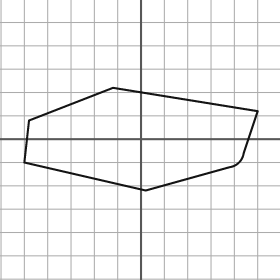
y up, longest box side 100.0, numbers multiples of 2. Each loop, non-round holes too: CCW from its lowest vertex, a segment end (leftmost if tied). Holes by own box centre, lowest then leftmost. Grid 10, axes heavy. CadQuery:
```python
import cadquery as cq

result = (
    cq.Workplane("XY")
    .moveTo(2.0, -22.0)
    .lineTo(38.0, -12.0)
    .threePointArc((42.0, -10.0), (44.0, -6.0))
    .lineTo(50.0, 12.0)
    .lineTo(-12.0, 22.0)
    .lineTo(-48.0, 8.0)
    .lineTo(-50.0, -10.0)
    .close()
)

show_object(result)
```